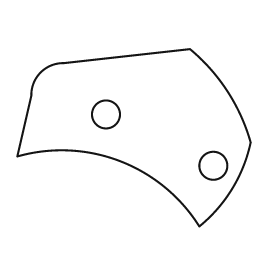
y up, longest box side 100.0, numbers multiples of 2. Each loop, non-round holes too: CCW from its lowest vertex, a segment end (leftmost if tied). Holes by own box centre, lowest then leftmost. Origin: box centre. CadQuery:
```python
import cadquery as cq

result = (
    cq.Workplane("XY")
    .moveTo(28.0, -38.0)
    .threePointArc((42.0, -22.0), (50.0, -2.0))
    .threePointArc((40.0, 20.0), (24.0, 38.0))
    .lineTo(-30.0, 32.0)
    .threePointArc((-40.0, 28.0), (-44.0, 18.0))
    .lineTo(-50.0, -8.0)
    .threePointArc((-6.0, -10.0), (28.0, -38.0))
    .close()
    .moveTo(34.0, -12.0)
    .circle(6.0)
    .moveTo(-12.0, 10.0)
    .circle(6.0)
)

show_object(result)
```